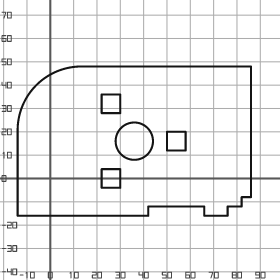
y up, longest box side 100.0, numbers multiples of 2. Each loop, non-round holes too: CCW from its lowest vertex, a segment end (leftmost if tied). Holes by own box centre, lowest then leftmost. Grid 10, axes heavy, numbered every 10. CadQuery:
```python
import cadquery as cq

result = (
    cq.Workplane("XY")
    .moveTo(-14.0, -16.0)
    .lineTo(42.0, -16.0)
    .lineTo(42.0, -12.0)
    .lineTo(66.0, -12.0)
    .lineTo(66.0, -16.0)
    .lineTo(76.0, -16.0)
    .lineTo(76.0, -12.0)
    .lineTo(82.0, -12.0)
    .lineTo(82.0, -8.0)
    .lineTo(86.0, -8.0)
    .lineTo(86.0, 48.0)
    .lineTo(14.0, 48.0)
    .threePointArc((-6.0, 40.0), (-14.0, 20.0))
    .close()
    .moveTo(22.0, -4.0)
    .lineTo(30.0, -4.0)
    .lineTo(30.0, 4.0)
    .lineTo(22.0, 4.0)
    .close()
    .moveTo(36.0, 16.0)
    .circle(8.0)
    .moveTo(50.0, 12.0)
    .lineTo(58.0, 12.0)
    .lineTo(58.0, 20.0)
    .lineTo(50.0, 20.0)
    .close()
    .moveTo(22.0, 28.0)
    .lineTo(30.0, 28.0)
    .lineTo(30.0, 36.0)
    .lineTo(22.0, 36.0)
    .close()
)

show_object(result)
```